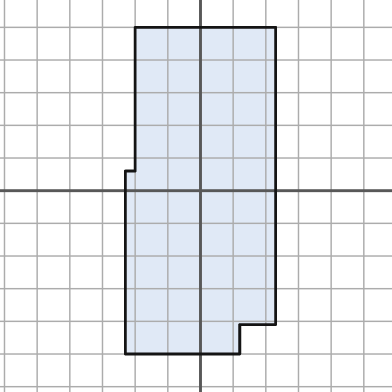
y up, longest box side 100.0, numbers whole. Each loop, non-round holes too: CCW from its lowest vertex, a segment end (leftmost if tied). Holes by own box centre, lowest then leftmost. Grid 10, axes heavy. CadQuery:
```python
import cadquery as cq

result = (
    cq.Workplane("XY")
    .moveTo(-23.0, -50.0)
    .lineTo(12.0, -50.0)
    .lineTo(12.0, -41.0)
    .lineTo(23.0, -41.0)
    .lineTo(23.0, 50.0)
    .lineTo(-20.0, 50.0)
    .lineTo(-20.0, 6.0)
    .lineTo(-23.0, 6.0)
    .close()
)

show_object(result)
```